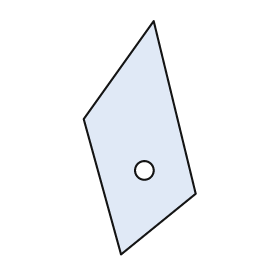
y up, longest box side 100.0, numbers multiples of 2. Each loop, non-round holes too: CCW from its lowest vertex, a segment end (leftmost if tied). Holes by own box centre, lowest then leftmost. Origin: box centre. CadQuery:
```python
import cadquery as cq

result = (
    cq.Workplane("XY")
    .moveTo(-8.0, -50.0)
    .lineTo(24.0, -24.0)
    .lineTo(6.0, 50.0)
    .lineTo(-24.0, 8.0)
    .close()
    .moveTo(2.0, -14.0)
    .circle(4.0)
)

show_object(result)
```